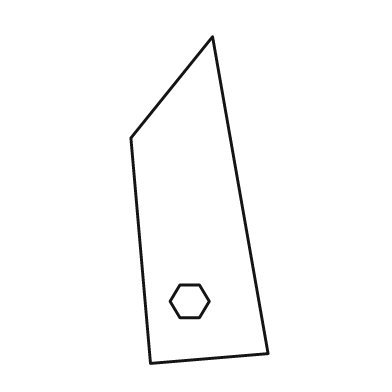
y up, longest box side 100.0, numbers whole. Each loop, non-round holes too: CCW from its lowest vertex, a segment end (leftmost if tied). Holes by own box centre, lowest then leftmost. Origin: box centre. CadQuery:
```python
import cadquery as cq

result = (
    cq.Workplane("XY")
    .moveTo(-15.0, -50.0)
    .lineTo(21.0, -47.0)
    .lineTo(4.0, 50.0)
    .lineTo(-21.0, 19.0)
    .close()
    .moveTo(-6.0, -36.0)
    .lineTo(0.0, -36.0)
    .lineTo(3.0, -31.0)
    .lineTo(0.0, -26.0)
    .lineTo(-6.0, -26.0)
    .lineTo(-9.0, -31.0)
    .close()
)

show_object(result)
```